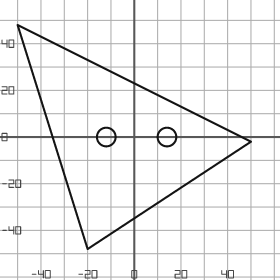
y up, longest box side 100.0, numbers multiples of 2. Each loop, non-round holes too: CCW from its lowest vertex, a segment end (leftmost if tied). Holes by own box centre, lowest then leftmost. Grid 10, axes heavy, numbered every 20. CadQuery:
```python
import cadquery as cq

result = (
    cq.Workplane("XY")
    .moveTo(-20.0, -48.0)
    .lineTo(50.0, -2.0)
    .lineTo(-50.0, 48.0)
    .close()
    .moveTo(-12.0, 0.0)
    .circle(4.0)
    .moveTo(14.0, 0.0)
    .circle(4.0)
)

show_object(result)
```